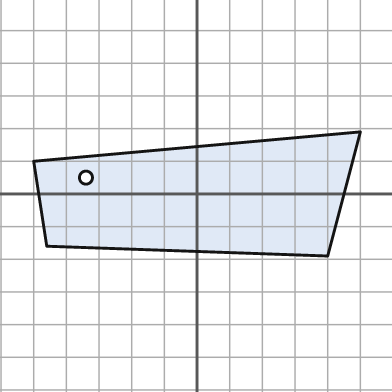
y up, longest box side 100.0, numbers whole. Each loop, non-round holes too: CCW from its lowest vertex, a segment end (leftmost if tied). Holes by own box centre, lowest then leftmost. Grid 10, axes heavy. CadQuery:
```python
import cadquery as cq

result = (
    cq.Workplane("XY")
    .moveTo(40.0, -19.0)
    .lineTo(50.0, 19.0)
    .lineTo(-50.0, 10.0)
    .lineTo(-46.0, -16.0)
    .close()
    .moveTo(-34.0, 5.0)
    .circle(2.0)
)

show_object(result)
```